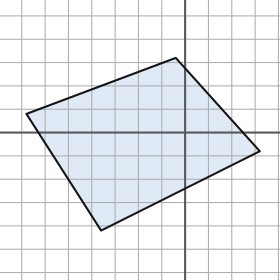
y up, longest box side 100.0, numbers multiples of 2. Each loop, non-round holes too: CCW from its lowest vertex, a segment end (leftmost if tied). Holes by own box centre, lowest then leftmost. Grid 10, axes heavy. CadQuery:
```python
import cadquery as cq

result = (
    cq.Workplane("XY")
    .moveTo(-36.0, -42.0)
    .lineTo(32.0, -8.0)
    .lineTo(-4.0, 32.0)
    .lineTo(-68.0, 8.0)
    .close()
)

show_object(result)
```